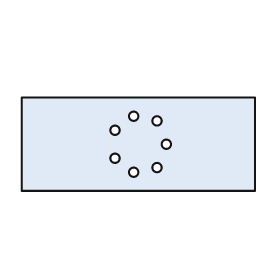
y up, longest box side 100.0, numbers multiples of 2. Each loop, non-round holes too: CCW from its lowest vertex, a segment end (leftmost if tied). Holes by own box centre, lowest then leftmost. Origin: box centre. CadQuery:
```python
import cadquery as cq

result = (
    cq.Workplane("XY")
    .moveTo(-50.0, -20.0)
    .lineTo(50.0, -20.0)
    .lineTo(50.0, 20.0)
    .lineTo(-50.0, 20.0)
    .close()
    .moveTo(-2.0, -12.0)
    .circle(2.0)
    .moveTo(8.0, -10.0)
    .circle(2.0)
    .moveTo(-10.0, -6.0)
    .circle(2.0)
    .moveTo(12.0, 0.0)
    .circle(2.0)
    .moveTo(-10.0, 6.0)
    .circle(2.0)
    .moveTo(8.0, 10.0)
    .circle(2.0)
    .moveTo(-2.0, 12.0)
    .circle(2.0)
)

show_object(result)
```